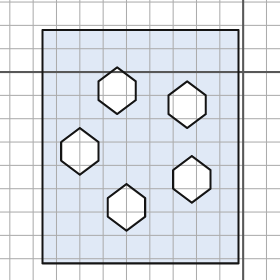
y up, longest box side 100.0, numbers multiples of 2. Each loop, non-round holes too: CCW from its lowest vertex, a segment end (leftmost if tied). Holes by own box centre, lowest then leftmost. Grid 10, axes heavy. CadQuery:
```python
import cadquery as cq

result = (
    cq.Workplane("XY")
    .moveTo(-86.0, -82.0)
    .lineTo(-2.0, -82.0)
    .lineTo(-2.0, 18.0)
    .lineTo(-86.0, 18.0)
    .close()
    .moveTo(-50.0, -68.0)
    .lineTo(-42.0, -62.0)
    .lineTo(-42.0, -54.0)
    .lineTo(-50.0, -48.0)
    .lineTo(-58.0, -54.0)
    .lineTo(-58.0, -62.0)
    .close()
    .moveTo(-22.0, -56.0)
    .lineTo(-14.0, -50.0)
    .lineTo(-14.0, -42.0)
    .lineTo(-22.0, -36.0)
    .lineTo(-30.0, -42.0)
    .lineTo(-30.0, -50.0)
    .close()
    .moveTo(-70.0, -44.0)
    .lineTo(-62.0, -38.0)
    .lineTo(-62.0, -30.0)
    .lineTo(-70.0, -24.0)
    .lineTo(-78.0, -30.0)
    .lineTo(-78.0, -38.0)
    .close()
    .moveTo(-24.0, -24.0)
    .lineTo(-16.0, -18.0)
    .lineTo(-16.0, -10.0)
    .lineTo(-24.0, -4.0)
    .lineTo(-32.0, -10.0)
    .lineTo(-32.0, -18.0)
    .close()
    .moveTo(-54.0, -18.0)
    .lineTo(-46.0, -12.0)
    .lineTo(-46.0, -4.0)
    .lineTo(-54.0, 2.0)
    .lineTo(-62.0, -4.0)
    .lineTo(-62.0, -12.0)
    .close()
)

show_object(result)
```